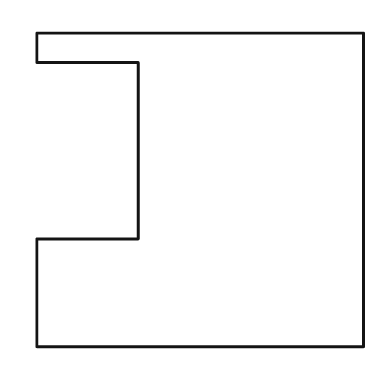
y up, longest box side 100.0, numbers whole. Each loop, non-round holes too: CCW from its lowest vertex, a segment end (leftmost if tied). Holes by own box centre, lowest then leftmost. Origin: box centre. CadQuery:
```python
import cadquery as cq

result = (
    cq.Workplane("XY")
    .moveTo(-50.0, -48.0)
    .lineTo(50.0, -48.0)
    .lineTo(50.0, 48.0)
    .lineTo(-50.0, 48.0)
    .lineTo(-50.0, 39.0)
    .lineTo(-19.0, 39.0)
    .lineTo(-19.0, -15.0)
    .lineTo(-50.0, -15.0)
    .close()
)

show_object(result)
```